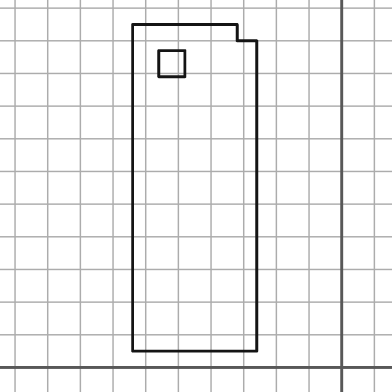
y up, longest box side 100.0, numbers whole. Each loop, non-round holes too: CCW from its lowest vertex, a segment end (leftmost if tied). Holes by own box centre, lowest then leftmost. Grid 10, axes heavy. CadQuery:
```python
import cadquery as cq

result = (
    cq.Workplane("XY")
    .moveTo(-64.0, 5.0)
    .lineTo(-26.0, 5.0)
    .lineTo(-26.0, 100.0)
    .lineTo(-32.0, 100.0)
    .lineTo(-32.0, 105.0)
    .lineTo(-64.0, 105.0)
    .close()
    .moveTo(-56.0, 89.0)
    .lineTo(-48.0, 89.0)
    .lineTo(-48.0, 97.0)
    .lineTo(-56.0, 97.0)
    .close()
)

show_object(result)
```